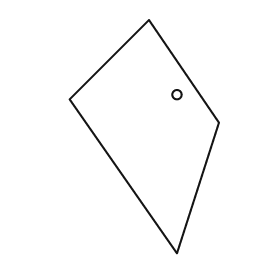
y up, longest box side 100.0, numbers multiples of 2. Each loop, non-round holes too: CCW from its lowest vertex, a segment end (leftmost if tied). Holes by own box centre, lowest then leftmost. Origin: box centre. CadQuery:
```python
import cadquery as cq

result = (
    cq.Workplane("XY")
    .moveTo(14.0, -50.0)
    .lineTo(32.0, 6.0)
    .lineTo(2.0, 50.0)
    .lineTo(-32.0, 16.0)
    .close()
    .moveTo(14.0, 18.0)
    .circle(2.0)
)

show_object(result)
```